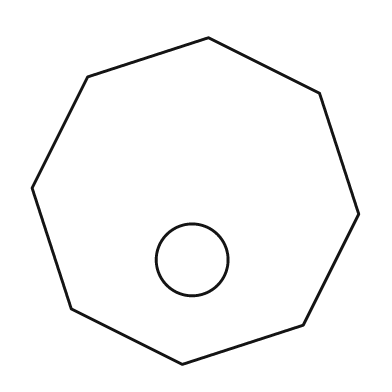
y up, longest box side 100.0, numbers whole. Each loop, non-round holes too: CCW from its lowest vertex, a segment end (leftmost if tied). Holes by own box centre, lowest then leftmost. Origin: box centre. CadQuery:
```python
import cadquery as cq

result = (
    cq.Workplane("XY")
    .moveTo(-4.0, -50.0)
    .lineTo(33.0, -38.0)
    .lineTo(50.0, -4.0)
    .lineTo(38.0, 33.0)
    .lineTo(4.0, 50.0)
    .lineTo(-33.0, 38.0)
    .lineTo(-50.0, 4.0)
    .lineTo(-38.0, -33.0)
    .close()
    .moveTo(-1.0, -18.0)
    .circle(11.0)
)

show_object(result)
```